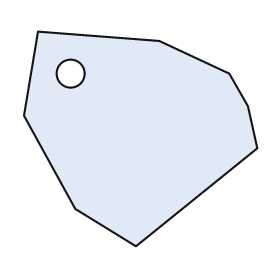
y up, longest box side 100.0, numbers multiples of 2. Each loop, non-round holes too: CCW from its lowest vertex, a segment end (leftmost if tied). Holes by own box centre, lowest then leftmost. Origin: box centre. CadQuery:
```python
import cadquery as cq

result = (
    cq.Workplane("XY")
    .moveTo(-2.0, -46.0)
    .lineTo(50.0, -4.0)
    .lineTo(46.0, 14.0)
    .lineTo(38.0, 28.0)
    .lineTo(8.0, 42.0)
    .lineTo(-44.0, 46.0)
    .lineTo(-50.0, 10.0)
    .lineTo(-28.0, -30.0)
    .close()
    .moveTo(-30.0, 28.0)
    .circle(6.0)
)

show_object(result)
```